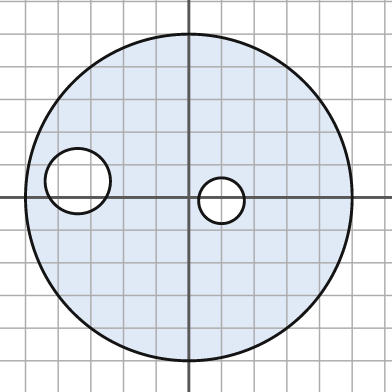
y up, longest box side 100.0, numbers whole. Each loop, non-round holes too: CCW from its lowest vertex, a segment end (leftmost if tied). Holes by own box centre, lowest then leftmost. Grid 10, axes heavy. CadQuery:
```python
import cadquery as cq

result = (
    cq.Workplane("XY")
    .moveTo(0.0, 0.0)
    .circle(50.0)
    .moveTo(10.0, -1.0)
    .circle(7.0)
    .moveTo(-34.0, 5.0)
    .circle(10.0)
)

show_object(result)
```